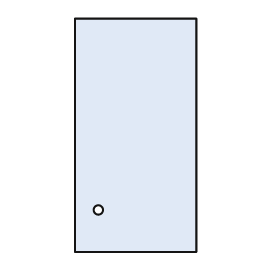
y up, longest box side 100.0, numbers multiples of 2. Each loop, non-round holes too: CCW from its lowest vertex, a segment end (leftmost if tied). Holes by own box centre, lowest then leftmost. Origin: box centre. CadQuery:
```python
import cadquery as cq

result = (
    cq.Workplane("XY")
    .moveTo(-26.0, -50.0)
    .lineTo(26.0, -50.0)
    .lineTo(26.0, 50.0)
    .lineTo(-26.0, 50.0)
    .close()
    .moveTo(-16.0, -32.0)
    .circle(2.0)
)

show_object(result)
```